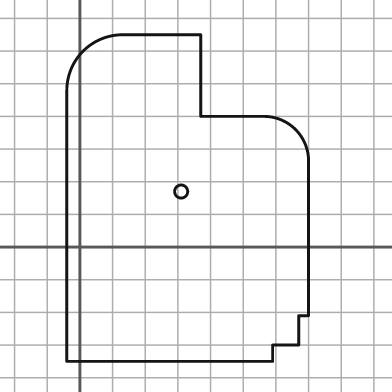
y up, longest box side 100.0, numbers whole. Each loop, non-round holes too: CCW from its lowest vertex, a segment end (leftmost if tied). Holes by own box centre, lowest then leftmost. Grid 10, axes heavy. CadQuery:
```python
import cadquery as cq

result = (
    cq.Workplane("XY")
    .moveTo(-4.0, -35.0)
    .lineTo(59.0, -35.0)
    .lineTo(59.0, -30.0)
    .lineTo(67.0, -30.0)
    .lineTo(67.0, -21.0)
    .lineTo(70.0, -21.0)
    .lineTo(70.0, 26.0)
    .threePointArc((66.0, 36.0), (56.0, 40.0))
    .lineTo(37.0, 40.0)
    .lineTo(37.0, 65.0)
    .lineTo(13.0, 65.0)
    .threePointArc((1.0, 60.0), (-4.0, 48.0))
    .close()
    .moveTo(31.0, 17.0)
    .circle(2.0)
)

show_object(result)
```